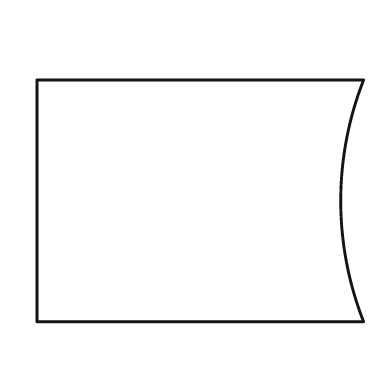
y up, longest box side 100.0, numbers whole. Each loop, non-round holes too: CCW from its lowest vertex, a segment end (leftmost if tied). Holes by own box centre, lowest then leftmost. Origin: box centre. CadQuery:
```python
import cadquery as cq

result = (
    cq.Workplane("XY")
    .moveTo(-50.0, -37.0)
    .lineTo(50.0, -37.0)
    .threePointArc((43.0, 0.0), (50.0, 37.0))
    .lineTo(-50.0, 37.0)
    .close()
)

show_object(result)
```